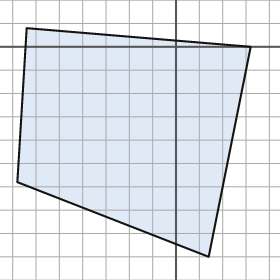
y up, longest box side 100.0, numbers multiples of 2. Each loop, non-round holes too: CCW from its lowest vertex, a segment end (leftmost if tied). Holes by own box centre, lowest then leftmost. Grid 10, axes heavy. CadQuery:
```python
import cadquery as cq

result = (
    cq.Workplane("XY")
    .moveTo(14.0, -90.0)
    .lineTo(32.0, 0.0)
    .lineTo(-64.0, 8.0)
    .lineTo(-68.0, -58.0)
    .close()
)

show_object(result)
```